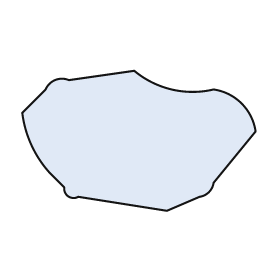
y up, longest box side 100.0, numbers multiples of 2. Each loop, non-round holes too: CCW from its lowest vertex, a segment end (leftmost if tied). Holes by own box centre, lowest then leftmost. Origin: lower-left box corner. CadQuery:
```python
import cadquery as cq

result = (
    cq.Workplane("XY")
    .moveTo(62.0, 0.0)
    .lineTo(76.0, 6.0)
    .threePointArc((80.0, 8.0), (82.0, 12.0))
    .lineTo(100.0, 34.0)
    .threePointArc((94.0, 46.0), (82.0, 52.0))
    .threePointArc((64.0, 52.0), (48.0, 60.0))
    .lineTo(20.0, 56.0)
    .threePointArc((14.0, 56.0), (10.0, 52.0))
    .lineTo(0.0, 42.0)
    .threePointArc((4.0, 28.0), (12.0, 16.0))
    .lineTo(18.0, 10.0)
    .threePointArc((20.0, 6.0), (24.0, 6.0))
    .close()
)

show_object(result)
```